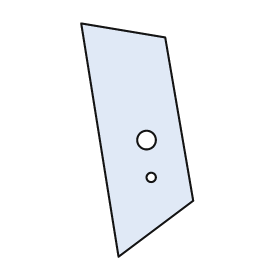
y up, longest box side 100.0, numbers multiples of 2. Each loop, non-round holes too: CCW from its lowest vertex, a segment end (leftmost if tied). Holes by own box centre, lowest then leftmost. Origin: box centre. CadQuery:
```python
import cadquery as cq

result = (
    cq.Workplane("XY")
    .moveTo(-8.0, -50.0)
    .lineTo(24.0, -26.0)
    .lineTo(12.0, 44.0)
    .lineTo(-24.0, 50.0)
    .close()
    .moveTo(6.0, -16.0)
    .circle(2.0)
    .moveTo(4.0, 0.0)
    .circle(4.0)
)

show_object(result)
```